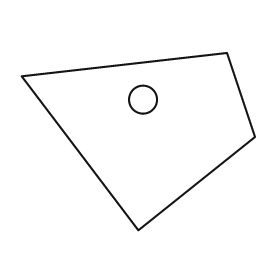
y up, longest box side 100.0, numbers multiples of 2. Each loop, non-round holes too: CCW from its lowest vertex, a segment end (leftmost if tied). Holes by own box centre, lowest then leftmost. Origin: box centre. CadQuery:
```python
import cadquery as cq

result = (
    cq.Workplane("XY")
    .moveTo(0.0, -38.0)
    .lineTo(50.0, 2.0)
    .lineTo(38.0, 38.0)
    .lineTo(-50.0, 28.0)
    .close()
    .moveTo(2.0, 18.0)
    .circle(6.0)
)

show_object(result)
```